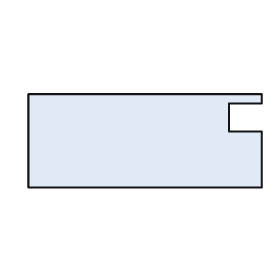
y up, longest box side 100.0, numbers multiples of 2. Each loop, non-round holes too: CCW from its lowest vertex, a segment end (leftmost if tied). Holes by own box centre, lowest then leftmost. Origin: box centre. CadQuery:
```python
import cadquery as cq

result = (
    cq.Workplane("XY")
    .moveTo(-50.0, -20.0)
    .lineTo(50.0, -20.0)
    .lineTo(50.0, 4.0)
    .lineTo(36.0, 4.0)
    .lineTo(36.0, 16.0)
    .lineTo(50.0, 16.0)
    .lineTo(50.0, 20.0)
    .lineTo(-50.0, 20.0)
    .close()
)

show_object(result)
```